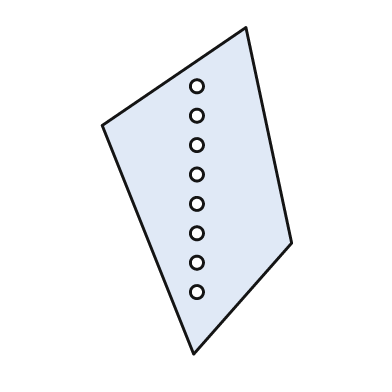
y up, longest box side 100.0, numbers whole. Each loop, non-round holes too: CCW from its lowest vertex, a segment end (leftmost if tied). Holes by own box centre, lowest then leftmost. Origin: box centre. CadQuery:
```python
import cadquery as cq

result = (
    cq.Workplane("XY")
    .moveTo(-1.0, -50.0)
    .lineTo(29.0, -16.0)
    .lineTo(15.0, 50.0)
    .lineTo(-29.0, 20.0)
    .close()
    .moveTo(0.0, -31.0)
    .circle(2.0)
    .moveTo(0.0, -22.0)
    .circle(2.0)
    .moveTo(0.0, -13.0)
    .circle(2.0)
    .moveTo(0.0, -4.0)
    .circle(2.0)
    .moveTo(0.0, 5.0)
    .circle(2.0)
    .moveTo(0.0, 14.0)
    .circle(2.0)
    .moveTo(0.0, 23.0)
    .circle(2.0)
    .moveTo(0.0, 32.0)
    .circle(2.0)
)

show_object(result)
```